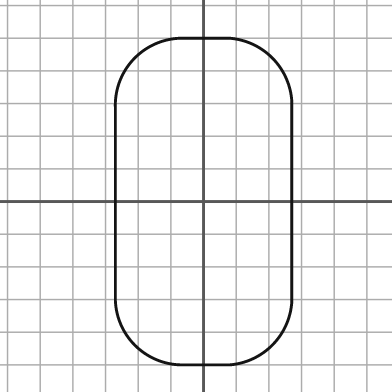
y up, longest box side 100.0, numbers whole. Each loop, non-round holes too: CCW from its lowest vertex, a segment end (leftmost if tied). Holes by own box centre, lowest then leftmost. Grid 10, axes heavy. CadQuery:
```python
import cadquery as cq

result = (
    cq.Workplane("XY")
    .moveTo(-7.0, -50.0)
    .lineTo(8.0, -50.0)
    .threePointArc((21.0, -44.0), (27.0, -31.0))
    .lineTo(27.0, 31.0)
    .threePointArc((21.0, 44.0), (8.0, 50.0))
    .lineTo(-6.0, 50.0)
    .threePointArc((-21.0, 44.0), (-27.0, 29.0))
    .lineTo(-27.0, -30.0)
    .threePointArc((-21.0, -44.0), (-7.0, -50.0))
    .close()
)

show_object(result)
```